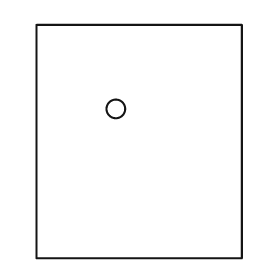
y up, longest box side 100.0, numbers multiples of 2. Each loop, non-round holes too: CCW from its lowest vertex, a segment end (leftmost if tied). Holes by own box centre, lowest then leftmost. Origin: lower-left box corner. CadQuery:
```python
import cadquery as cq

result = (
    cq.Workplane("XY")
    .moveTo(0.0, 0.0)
    .lineTo(88.0, 0.0)
    .lineTo(88.0, 100.0)
    .lineTo(0.0, 100.0)
    .close()
    .moveTo(34.0, 64.0)
    .circle(4.0)
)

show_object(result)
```